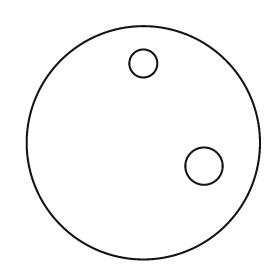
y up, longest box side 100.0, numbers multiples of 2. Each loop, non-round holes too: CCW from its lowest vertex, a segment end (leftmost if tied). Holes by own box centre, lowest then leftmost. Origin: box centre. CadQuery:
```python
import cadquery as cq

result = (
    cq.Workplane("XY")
    .moveTo(0.0, 0.0)
    .circle(50.0)
    .moveTo(26.0, -10.0)
    .circle(8.0)
    .moveTo(0.0, 34.0)
    .circle(6.0)
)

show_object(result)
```